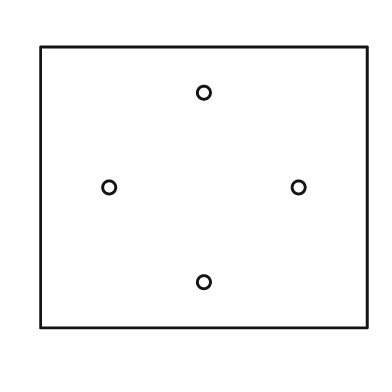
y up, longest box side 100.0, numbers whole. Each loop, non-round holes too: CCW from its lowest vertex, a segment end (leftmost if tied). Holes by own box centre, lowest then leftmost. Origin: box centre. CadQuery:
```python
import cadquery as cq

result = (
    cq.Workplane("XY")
    .moveTo(-50.0, -43.0)
    .lineTo(50.0, -43.0)
    .lineTo(50.0, 43.0)
    .lineTo(-50.0, 43.0)
    .close()
    .moveTo(0.0, -29.0)
    .circle(2.0)
    .moveTo(-29.0, 0.0)
    .circle(2.0)
    .moveTo(29.0, 0.0)
    .circle(2.0)
    .moveTo(0.0, 29.0)
    .circle(2.0)
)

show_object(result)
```